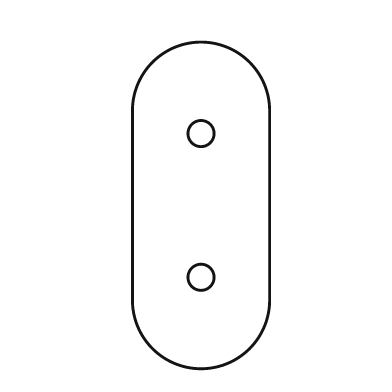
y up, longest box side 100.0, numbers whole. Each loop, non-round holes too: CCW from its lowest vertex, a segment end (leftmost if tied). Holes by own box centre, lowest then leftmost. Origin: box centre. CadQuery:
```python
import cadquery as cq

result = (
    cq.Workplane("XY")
    .moveTo(-21.0, -29.0)
    .threePointArc((0.0, -50.0), (21.0, -29.0))
    .lineTo(21.0, 29.0)
    .threePointArc((0.0, 50.0), (-21.0, 29.0))
    .close()
    .moveTo(0.0, -22.0)
    .circle(4.0)
    .moveTo(0.0, 22.0)
    .circle(4.0)
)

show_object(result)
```